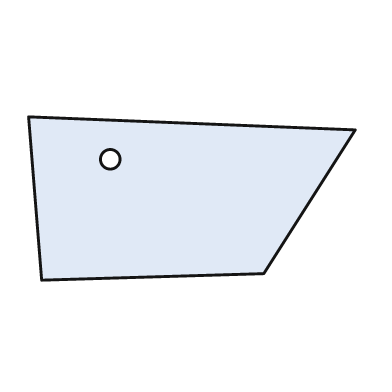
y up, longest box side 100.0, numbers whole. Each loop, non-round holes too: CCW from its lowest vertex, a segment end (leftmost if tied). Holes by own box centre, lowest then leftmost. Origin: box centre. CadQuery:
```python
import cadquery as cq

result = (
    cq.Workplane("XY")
    .moveTo(-46.0, -25.0)
    .lineTo(22.0, -23.0)
    .lineTo(50.0, 21.0)
    .lineTo(-50.0, 25.0)
    .close()
    .moveTo(-25.0, 12.0)
    .circle(3.0)
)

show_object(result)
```